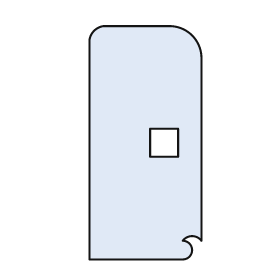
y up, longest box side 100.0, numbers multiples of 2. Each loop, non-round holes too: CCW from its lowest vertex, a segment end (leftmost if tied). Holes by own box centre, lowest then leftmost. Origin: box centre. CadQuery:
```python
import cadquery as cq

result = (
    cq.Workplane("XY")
    .moveTo(-24.0, -50.0)
    .lineTo(16.0, -50.0)
    .threePointArc((20.0, -46.0), (16.0, -42.0))
    .threePointArc((20.0, -40.0), (24.0, -42.0))
    .lineTo(24.0, 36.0)
    .threePointArc((20.0, 46.0), (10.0, 50.0))
    .lineTo(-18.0, 50.0)
    .threePointArc((-22.0, 48.0), (-24.0, 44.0))
    .close()
    .moveTo(2.0, -6.0)
    .lineTo(14.0, -6.0)
    .lineTo(14.0, 6.0)
    .lineTo(2.0, 6.0)
    .close()
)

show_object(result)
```